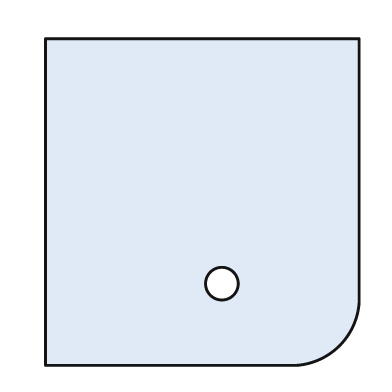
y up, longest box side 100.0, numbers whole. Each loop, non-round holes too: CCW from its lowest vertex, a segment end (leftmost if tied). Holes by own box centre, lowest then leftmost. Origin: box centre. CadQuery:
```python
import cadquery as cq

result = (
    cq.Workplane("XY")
    .moveTo(-48.0, -50.0)
    .lineTo(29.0, -50.0)
    .threePointArc((42.0, -44.0), (48.0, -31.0))
    .lineTo(48.0, 50.0)
    .lineTo(-48.0, 50.0)
    .close()
    .moveTo(6.0, -25.0)
    .circle(5.0)
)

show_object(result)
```